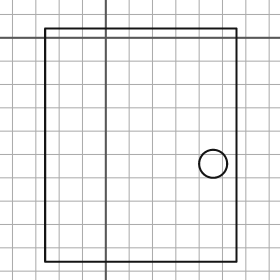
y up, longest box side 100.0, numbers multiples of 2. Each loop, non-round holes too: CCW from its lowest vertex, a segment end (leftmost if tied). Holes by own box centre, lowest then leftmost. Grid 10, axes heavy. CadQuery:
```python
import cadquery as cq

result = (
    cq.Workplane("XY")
    .moveTo(-26.0, -96.0)
    .lineTo(56.0, -96.0)
    .lineTo(56.0, 4.0)
    .lineTo(-26.0, 4.0)
    .close()
    .moveTo(46.0, -54.0)
    .circle(6.0)
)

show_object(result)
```